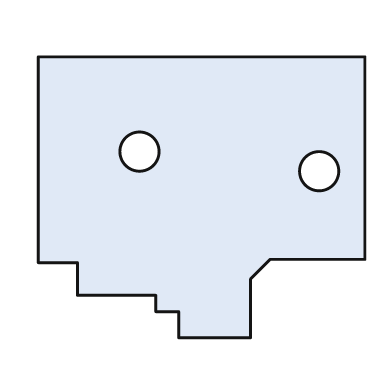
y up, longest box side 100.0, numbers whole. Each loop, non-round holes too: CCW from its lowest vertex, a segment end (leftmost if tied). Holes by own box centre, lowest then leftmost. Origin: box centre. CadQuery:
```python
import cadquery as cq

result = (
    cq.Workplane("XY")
    .moveTo(-7.0, -43.0)
    .lineTo(15.0, -43.0)
    .lineTo(15.0, -25.0)
    .lineTo(21.0, -19.0)
    .lineTo(50.0, -19.0)
    .lineTo(50.0, 43.0)
    .lineTo(-50.0, 43.0)
    .lineTo(-50.0, -20.0)
    .lineTo(-38.0, -20.0)
    .lineTo(-38.0, -30.0)
    .lineTo(-14.0, -30.0)
    .lineTo(-14.0, -35.0)
    .lineTo(-7.0, -35.0)
    .close()
    .moveTo(36.0, 8.0)
    .circle(6.0)
    .moveTo(-19.0, 14.0)
    .circle(6.0)
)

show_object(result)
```